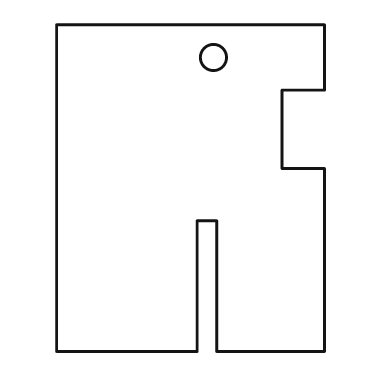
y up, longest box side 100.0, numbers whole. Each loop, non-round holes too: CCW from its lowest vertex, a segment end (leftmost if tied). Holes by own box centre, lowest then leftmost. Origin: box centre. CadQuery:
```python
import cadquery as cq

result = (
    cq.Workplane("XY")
    .moveTo(-41.0, -50.0)
    .lineTo(2.0, -50.0)
    .lineTo(2.0, -10.0)
    .lineTo(8.0, -10.0)
    .lineTo(8.0, -50.0)
    .lineTo(41.0, -50.0)
    .lineTo(41.0, 6.0)
    .lineTo(28.0, 6.0)
    .lineTo(28.0, 30.0)
    .lineTo(41.0, 30.0)
    .lineTo(41.0, 50.0)
    .lineTo(-41.0, 50.0)
    .close()
    .moveTo(7.0, 40.0)
    .circle(4.0)
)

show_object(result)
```